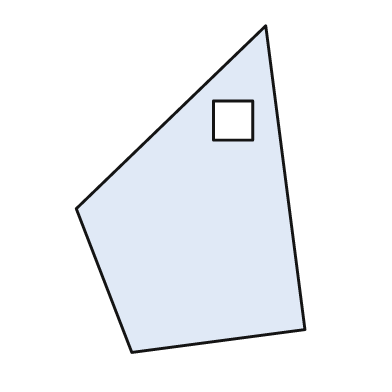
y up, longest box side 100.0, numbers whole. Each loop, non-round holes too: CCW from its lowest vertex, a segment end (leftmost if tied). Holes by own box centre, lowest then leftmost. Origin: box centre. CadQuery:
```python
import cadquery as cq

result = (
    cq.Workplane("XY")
    .moveTo(-18.0, -50.0)
    .lineTo(35.0, -43.0)
    .lineTo(23.0, 50.0)
    .lineTo(-35.0, -6.0)
    .close()
    .moveTo(7.0, 15.0)
    .lineTo(19.0, 15.0)
    .lineTo(19.0, 27.0)
    .lineTo(7.0, 27.0)
    .close()
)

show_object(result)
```